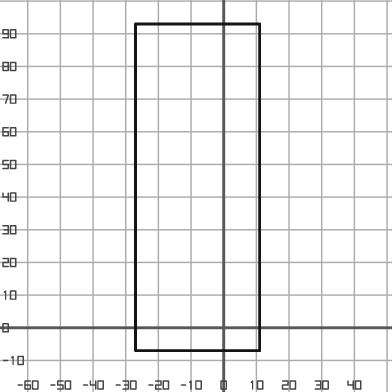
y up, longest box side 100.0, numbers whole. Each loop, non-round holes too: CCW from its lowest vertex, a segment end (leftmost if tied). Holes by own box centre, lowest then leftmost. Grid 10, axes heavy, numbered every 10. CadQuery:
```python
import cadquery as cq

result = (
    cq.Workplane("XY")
    .moveTo(-27.0, -7.0)
    .lineTo(11.0, -7.0)
    .lineTo(11.0, 93.0)
    .lineTo(-27.0, 93.0)
    .close()
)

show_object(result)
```